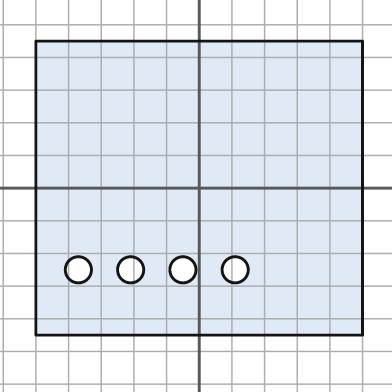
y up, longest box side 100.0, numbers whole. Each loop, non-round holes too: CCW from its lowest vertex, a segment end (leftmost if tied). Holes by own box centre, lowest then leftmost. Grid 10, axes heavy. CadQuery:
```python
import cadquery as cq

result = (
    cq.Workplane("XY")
    .moveTo(-50.0, -45.0)
    .lineTo(50.0, -45.0)
    .lineTo(50.0, 45.0)
    .lineTo(-50.0, 45.0)
    .close()
    .moveTo(-37.0, -25.0)
    .circle(4.0)
    .moveTo(-21.0, -25.0)
    .circle(4.0)
    .moveTo(-5.0, -25.0)
    .circle(4.0)
    .moveTo(11.0, -25.0)
    .circle(4.0)
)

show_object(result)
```